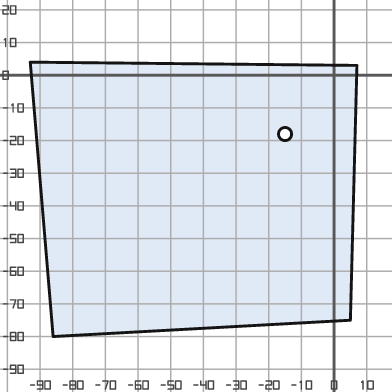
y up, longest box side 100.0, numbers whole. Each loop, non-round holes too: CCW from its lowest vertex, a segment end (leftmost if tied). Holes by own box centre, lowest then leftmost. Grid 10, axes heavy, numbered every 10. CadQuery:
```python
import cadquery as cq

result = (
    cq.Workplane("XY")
    .moveTo(-86.0, -80.0)
    .lineTo(5.0, -75.0)
    .lineTo(7.0, 3.0)
    .lineTo(-93.0, 4.0)
    .close()
    .moveTo(-15.0, -18.0)
    .circle(2.0)
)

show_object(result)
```